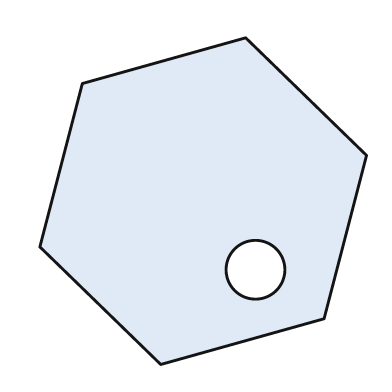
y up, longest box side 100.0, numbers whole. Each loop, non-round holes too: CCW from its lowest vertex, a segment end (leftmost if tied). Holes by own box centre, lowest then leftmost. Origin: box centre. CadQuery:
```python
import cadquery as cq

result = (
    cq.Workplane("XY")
    .moveTo(-13.0, -50.0)
    .lineTo(37.0, -36.0)
    .lineTo(50.0, 14.0)
    .lineTo(13.0, 50.0)
    .lineTo(-37.0, 36.0)
    .lineTo(-50.0, -14.0)
    .close()
    .moveTo(16.0, -21.0)
    .circle(9.0)
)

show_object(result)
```